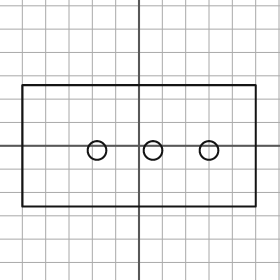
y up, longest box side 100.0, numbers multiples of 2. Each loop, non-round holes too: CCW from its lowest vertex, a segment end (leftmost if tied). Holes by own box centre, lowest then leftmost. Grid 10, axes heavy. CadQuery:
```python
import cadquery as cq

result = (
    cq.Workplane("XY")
    .moveTo(-50.0, -26.0)
    .lineTo(50.0, -26.0)
    .lineTo(50.0, 26.0)
    .lineTo(-50.0, 26.0)
    .close()
    .moveTo(-18.0, -2.0)
    .circle(4.0)
    .moveTo(6.0, -2.0)
    .circle(4.0)
    .moveTo(30.0, -2.0)
    .circle(4.0)
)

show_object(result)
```